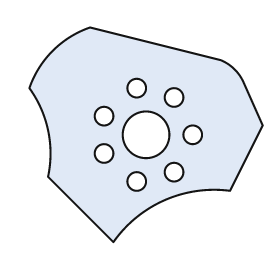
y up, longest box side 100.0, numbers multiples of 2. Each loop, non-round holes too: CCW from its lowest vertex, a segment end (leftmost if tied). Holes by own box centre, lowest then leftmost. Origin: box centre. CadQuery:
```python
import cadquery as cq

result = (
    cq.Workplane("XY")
    .moveTo(-14.0, -46.0)
    .threePointArc((8.0, -28.0), (36.0, -24.0))
    .lineTo(50.0, 4.0)
    .lineTo(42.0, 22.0)
    .threePointArc((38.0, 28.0), (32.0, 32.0))
    .lineTo(-24.0, 46.0)
    .threePointArc((-40.0, 36.0), (-50.0, 20.0))
    .threePointArc((-42.0, 2.0), (-42.0, -18.0))
    .close()
    .moveTo(-4.0, -20.0)
    .circle(4.0)
    .moveTo(12.0, -16.0)
    .circle(4.0)
    .moveTo(-18.0, -8.0)
    .circle(4.0)
    .moveTo(0.0, 0.0)
    .circle(10.0)
    .moveTo(20.0, 0.0)
    .circle(4.0)
    .moveTo(-18.0, 8.0)
    .circle(4.0)
    .moveTo(12.0, 16.0)
    .circle(4.0)
    .moveTo(-4.0, 20.0)
    .circle(4.0)
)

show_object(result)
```